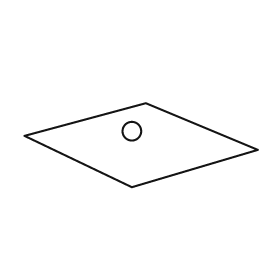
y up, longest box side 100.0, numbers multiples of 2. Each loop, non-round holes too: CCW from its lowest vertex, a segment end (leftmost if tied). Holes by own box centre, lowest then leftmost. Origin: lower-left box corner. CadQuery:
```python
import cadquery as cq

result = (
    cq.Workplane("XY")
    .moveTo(46.0, 0.0)
    .lineTo(100.0, 16.0)
    .lineTo(52.0, 36.0)
    .lineTo(0.0, 22.0)
    .close()
    .moveTo(46.0, 24.0)
    .circle(4.0)
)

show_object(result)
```